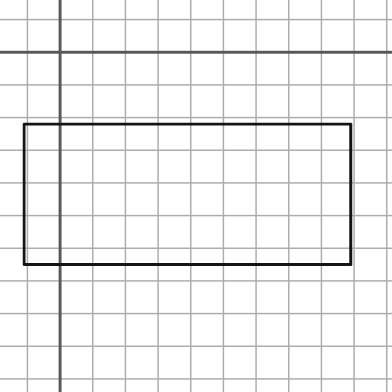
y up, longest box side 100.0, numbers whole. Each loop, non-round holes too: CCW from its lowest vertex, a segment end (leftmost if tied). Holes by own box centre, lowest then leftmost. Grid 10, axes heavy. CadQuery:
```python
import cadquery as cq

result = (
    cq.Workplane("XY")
    .moveTo(-11.0, -65.0)
    .lineTo(89.0, -65.0)
    .lineTo(89.0, -22.0)
    .lineTo(-11.0, -22.0)
    .close()
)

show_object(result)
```